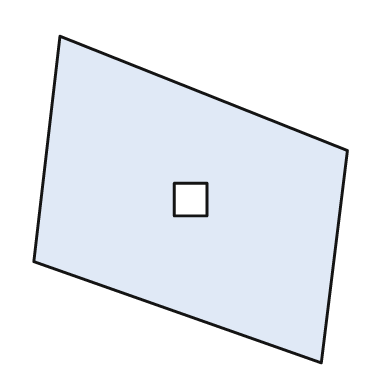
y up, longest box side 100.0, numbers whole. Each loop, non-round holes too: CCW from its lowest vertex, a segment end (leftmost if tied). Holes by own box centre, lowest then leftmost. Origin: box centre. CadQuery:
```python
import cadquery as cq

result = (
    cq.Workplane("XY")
    .moveTo(40.0, -50.0)
    .lineTo(48.0, 15.0)
    .lineTo(-40.0, 50.0)
    .lineTo(-48.0, -19.0)
    .close()
    .moveTo(-5.0, -5.0)
    .lineTo(5.0, -5.0)
    .lineTo(5.0, 5.0)
    .lineTo(-5.0, 5.0)
    .close()
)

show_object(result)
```